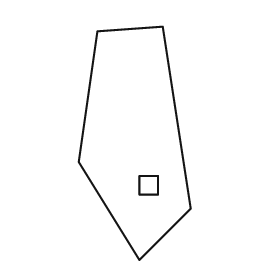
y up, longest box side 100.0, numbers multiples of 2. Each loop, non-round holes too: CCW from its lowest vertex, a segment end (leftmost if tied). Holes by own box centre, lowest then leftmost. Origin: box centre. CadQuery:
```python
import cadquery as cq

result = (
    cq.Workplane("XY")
    .moveTo(2.0, -50.0)
    .lineTo(24.0, -28.0)
    .lineTo(12.0, 50.0)
    .lineTo(-16.0, 48.0)
    .lineTo(-24.0, -8.0)
    .close()
    .moveTo(2.0, -22.0)
    .lineTo(10.0, -22.0)
    .lineTo(10.0, -14.0)
    .lineTo(2.0, -14.0)
    .close()
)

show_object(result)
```